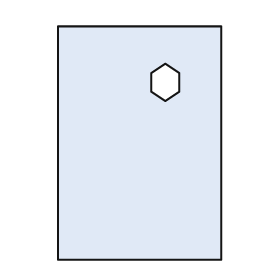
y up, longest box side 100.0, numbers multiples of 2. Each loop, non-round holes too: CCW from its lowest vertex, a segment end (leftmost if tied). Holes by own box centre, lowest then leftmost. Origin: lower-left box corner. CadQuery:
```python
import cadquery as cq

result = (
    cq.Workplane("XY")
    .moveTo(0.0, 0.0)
    .lineTo(70.0, 0.0)
    .lineTo(70.0, 100.0)
    .lineTo(0.0, 100.0)
    .close()
    .moveTo(46.0, 68.0)
    .lineTo(52.0, 72.0)
    .lineTo(52.0, 80.0)
    .lineTo(46.0, 84.0)
    .lineTo(40.0, 80.0)
    .lineTo(40.0, 72.0)
    .close()
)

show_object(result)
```